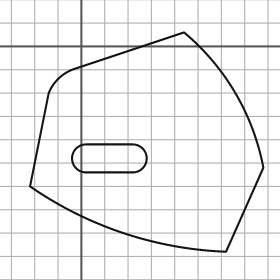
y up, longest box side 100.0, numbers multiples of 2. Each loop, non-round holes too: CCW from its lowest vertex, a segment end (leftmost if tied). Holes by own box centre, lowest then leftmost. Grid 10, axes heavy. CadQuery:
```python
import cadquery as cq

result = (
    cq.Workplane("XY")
    .moveTo(62.0, -88.0)
    .lineTo(78.0, -52.0)
    .threePointArc((66.0, -20.0), (44.0, 6.0))
    .lineTo(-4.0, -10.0)
    .threePointArc((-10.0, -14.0), (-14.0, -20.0))
    .lineTo(-22.0, -60.0)
    .threePointArc((18.0, -80.0), (62.0, -88.0))
    .close()
    .moveTo(2.0, -54.0)
    .lineTo(22.0, -54.0)
    .threePointArc((28.0, -48.0), (22.0, -42.0))
    .lineTo(2.0, -42.0)
    .threePointArc((-4.0, -48.0), (2.0, -54.0))
    .close()
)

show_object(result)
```